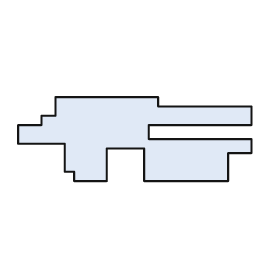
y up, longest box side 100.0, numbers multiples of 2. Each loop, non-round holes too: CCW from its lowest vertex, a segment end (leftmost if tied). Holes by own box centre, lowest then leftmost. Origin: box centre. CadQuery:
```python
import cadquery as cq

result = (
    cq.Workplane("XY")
    .moveTo(-26.0, -18.0)
    .lineTo(-12.0, -18.0)
    .lineTo(-12.0, -4.0)
    .lineTo(4.0, -4.0)
    .lineTo(4.0, -18.0)
    .lineTo(40.0, -18.0)
    .lineTo(40.0, -6.0)
    .lineTo(50.0, -6.0)
    .lineTo(50.0, 0.0)
    .lineTo(6.0, 0.0)
    .lineTo(6.0, 6.0)
    .lineTo(50.0, 6.0)
    .lineTo(50.0, 14.0)
    .lineTo(10.0, 14.0)
    .lineTo(10.0, 18.0)
    .lineTo(-34.0, 18.0)
    .lineTo(-34.0, 10.0)
    .lineTo(-40.0, 10.0)
    .lineTo(-40.0, 6.0)
    .lineTo(-50.0, 6.0)
    .lineTo(-50.0, -2.0)
    .lineTo(-30.0, -2.0)
    .lineTo(-30.0, -14.0)
    .lineTo(-26.0, -14.0)
    .close()
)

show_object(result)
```